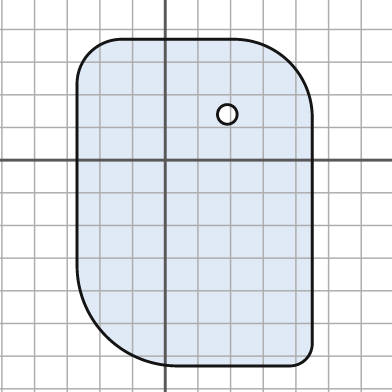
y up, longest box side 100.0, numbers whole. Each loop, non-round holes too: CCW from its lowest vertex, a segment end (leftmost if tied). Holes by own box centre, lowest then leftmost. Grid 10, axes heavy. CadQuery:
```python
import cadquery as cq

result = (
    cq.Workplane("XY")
    .moveTo(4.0, -63.0)
    .lineTo(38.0, -63.0)
    .threePointArc((43.0, -61.0), (45.0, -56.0))
    .lineTo(45.0, 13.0)
    .threePointArc((38.0, 30.0), (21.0, 37.0))
    .lineTo(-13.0, 37.0)
    .threePointArc((-23.0, 33.0), (-27.0, 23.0))
    .lineTo(-27.0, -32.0)
    .threePointArc((-18.0, -54.0), (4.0, -63.0))
    .close()
    .moveTo(19.0, 14.0)
    .circle(3.0)
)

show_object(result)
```